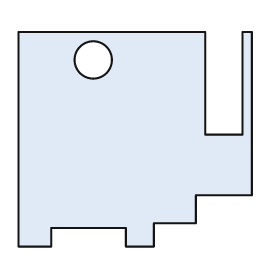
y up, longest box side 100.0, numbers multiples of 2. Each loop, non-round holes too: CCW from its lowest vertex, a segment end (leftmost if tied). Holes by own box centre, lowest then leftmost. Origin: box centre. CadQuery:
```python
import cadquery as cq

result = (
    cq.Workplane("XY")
    .moveTo(-50.0, -46.0)
    .lineTo(-36.0, -46.0)
    .lineTo(-36.0, -38.0)
    .lineTo(-4.0, -38.0)
    .lineTo(-4.0, -46.0)
    .lineTo(8.0, -46.0)
    .lineTo(8.0, -36.0)
    .lineTo(26.0, -36.0)
    .lineTo(26.0, -24.0)
    .lineTo(50.0, -24.0)
    .lineTo(50.0, 46.0)
    .lineTo(46.0, 46.0)
    .lineTo(46.0, 2.0)
    .lineTo(30.0, 2.0)
    .lineTo(30.0, 46.0)
    .lineTo(-50.0, 46.0)
    .close()
    .moveTo(-18.0, 34.0)
    .circle(8.0)
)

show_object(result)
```